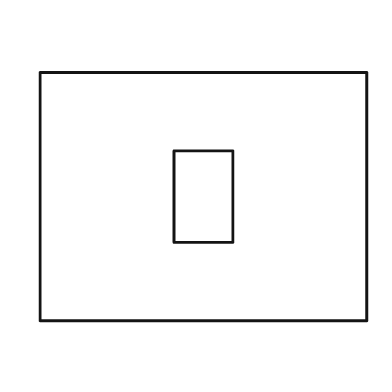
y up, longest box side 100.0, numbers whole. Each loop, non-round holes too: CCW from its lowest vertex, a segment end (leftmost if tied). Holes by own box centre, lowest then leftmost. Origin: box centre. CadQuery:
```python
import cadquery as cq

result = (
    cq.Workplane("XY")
    .moveTo(-50.0, -38.0)
    .lineTo(50.0, -38.0)
    .lineTo(50.0, 38.0)
    .lineTo(-50.0, 38.0)
    .close()
    .moveTo(-9.0, -14.0)
    .lineTo(9.0, -14.0)
    .lineTo(9.0, 14.0)
    .lineTo(-9.0, 14.0)
    .close()
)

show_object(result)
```